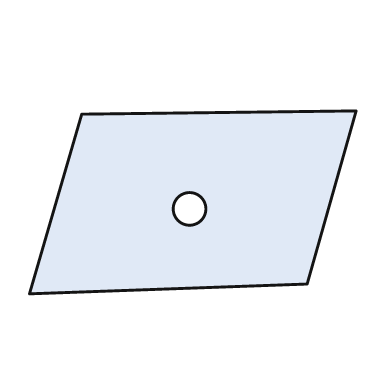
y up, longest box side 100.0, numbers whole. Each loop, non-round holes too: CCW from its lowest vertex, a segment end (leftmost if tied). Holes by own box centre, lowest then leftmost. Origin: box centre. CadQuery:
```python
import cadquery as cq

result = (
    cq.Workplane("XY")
    .moveTo(-50.0, -28.0)
    .lineTo(35.0, -25.0)
    .lineTo(50.0, 28.0)
    .lineTo(-34.0, 27.0)
    .close()
    .moveTo(-1.0, -2.0)
    .circle(5.0)
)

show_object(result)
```